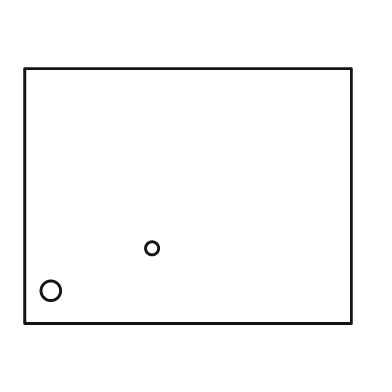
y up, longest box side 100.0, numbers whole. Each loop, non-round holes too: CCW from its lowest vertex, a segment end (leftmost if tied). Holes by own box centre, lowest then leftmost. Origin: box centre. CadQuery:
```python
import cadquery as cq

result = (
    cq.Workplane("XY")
    .moveTo(-50.0, -39.0)
    .lineTo(50.0, -39.0)
    .lineTo(50.0, 39.0)
    .lineTo(-50.0, 39.0)
    .close()
    .moveTo(-42.0, -29.0)
    .circle(3.0)
    .moveTo(-11.0, -16.0)
    .circle(2.0)
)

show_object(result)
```